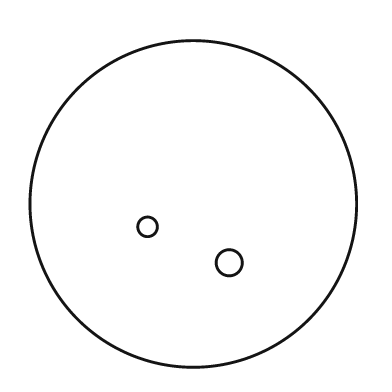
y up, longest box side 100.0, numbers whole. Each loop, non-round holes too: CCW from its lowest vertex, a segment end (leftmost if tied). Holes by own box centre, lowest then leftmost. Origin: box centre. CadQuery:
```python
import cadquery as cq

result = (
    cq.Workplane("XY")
    .moveTo(0.0, 0.0)
    .circle(50.0)
    .moveTo(11.0, -18.0)
    .circle(4.0)
    .moveTo(-14.0, -7.0)
    .circle(3.0)
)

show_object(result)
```